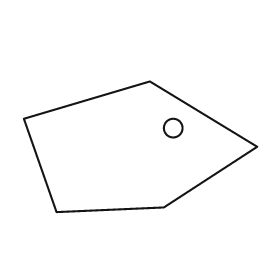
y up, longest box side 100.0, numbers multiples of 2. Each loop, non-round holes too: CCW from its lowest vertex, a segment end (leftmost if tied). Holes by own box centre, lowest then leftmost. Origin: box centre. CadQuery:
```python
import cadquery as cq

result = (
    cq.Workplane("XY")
    .moveTo(-36.0, -28.0)
    .lineTo(10.0, -26.0)
    .lineTo(50.0, 0.0)
    .lineTo(4.0, 28.0)
    .lineTo(-50.0, 12.0)
    .close()
    .moveTo(14.0, 8.0)
    .circle(4.0)
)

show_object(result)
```